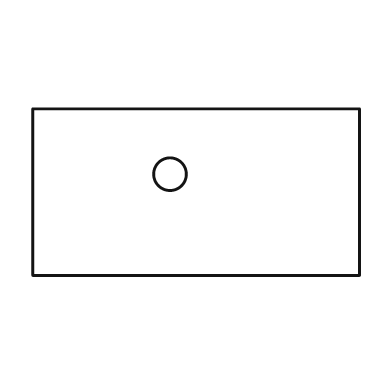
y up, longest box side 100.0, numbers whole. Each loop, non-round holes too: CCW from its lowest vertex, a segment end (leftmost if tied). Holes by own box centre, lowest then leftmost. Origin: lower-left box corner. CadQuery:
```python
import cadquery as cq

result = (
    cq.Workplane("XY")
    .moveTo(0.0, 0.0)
    .lineTo(100.0, 0.0)
    .lineTo(100.0, 51.0)
    .lineTo(0.0, 51.0)
    .close()
    .moveTo(42.0, 31.0)
    .circle(5.0)
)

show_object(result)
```